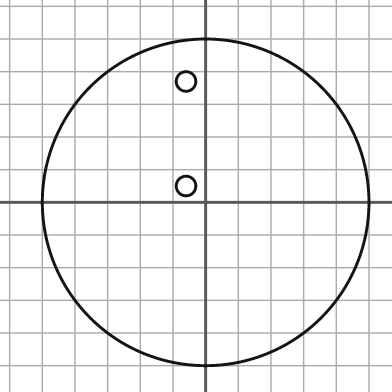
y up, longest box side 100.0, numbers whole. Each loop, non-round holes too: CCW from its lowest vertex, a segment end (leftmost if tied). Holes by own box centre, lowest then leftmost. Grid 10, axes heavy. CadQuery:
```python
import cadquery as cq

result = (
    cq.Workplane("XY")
    .moveTo(0.0, 0.0)
    .circle(50.0)
    .moveTo(-6.0, 5.0)
    .circle(3.0)
    .moveTo(-6.0, 37.0)
    .circle(3.0)
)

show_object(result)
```